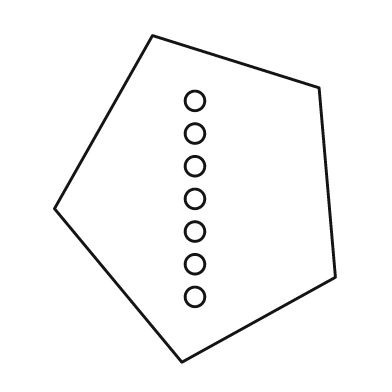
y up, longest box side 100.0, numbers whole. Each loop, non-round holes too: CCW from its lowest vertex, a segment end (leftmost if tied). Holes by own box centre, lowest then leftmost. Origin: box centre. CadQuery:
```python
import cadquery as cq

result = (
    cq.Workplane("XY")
    .moveTo(-4.0, -50.0)
    .lineTo(43.0, -24.0)
    .lineTo(38.0, 34.0)
    .lineTo(-13.0, 50.0)
    .lineTo(-43.0, -3.0)
    .close()
    .moveTo(0.0, -30.0)
    .circle(3.0)
    .moveTo(0.0, -20.0)
    .circle(3.0)
    .moveTo(0.0, -10.0)
    .circle(3.0)
    .moveTo(0.0, 0.0)
    .circle(3.0)
    .moveTo(0.0, 10.0)
    .circle(3.0)
    .moveTo(0.0, 20.0)
    .circle(3.0)
    .moveTo(0.0, 30.0)
    .circle(3.0)
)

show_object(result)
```